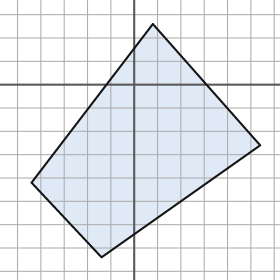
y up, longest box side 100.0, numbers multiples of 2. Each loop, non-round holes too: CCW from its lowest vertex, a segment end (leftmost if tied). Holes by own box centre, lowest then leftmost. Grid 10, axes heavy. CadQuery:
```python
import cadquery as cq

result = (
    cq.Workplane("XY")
    .moveTo(-14.0, -74.0)
    .lineTo(54.0, -26.0)
    .lineTo(8.0, 26.0)
    .lineTo(-44.0, -42.0)
    .close()
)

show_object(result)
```